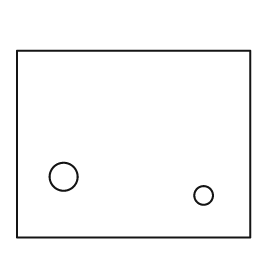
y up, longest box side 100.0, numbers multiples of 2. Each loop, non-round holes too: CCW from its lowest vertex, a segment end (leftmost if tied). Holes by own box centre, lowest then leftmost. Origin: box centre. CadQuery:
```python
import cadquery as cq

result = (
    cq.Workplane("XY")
    .moveTo(-50.0, -40.0)
    .lineTo(50.0, -40.0)
    .lineTo(50.0, 40.0)
    .lineTo(-50.0, 40.0)
    .close()
    .moveTo(30.0, -22.0)
    .circle(4.0)
    .moveTo(-30.0, -14.0)
    .circle(6.0)
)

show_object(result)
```